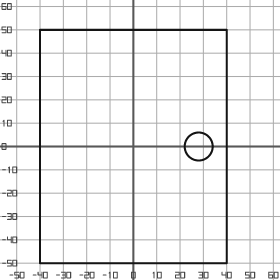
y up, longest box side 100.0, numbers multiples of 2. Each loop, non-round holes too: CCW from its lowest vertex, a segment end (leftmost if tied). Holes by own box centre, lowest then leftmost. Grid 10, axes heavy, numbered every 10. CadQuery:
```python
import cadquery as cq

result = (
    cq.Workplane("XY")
    .moveTo(-40.0, -50.0)
    .lineTo(40.0, -50.0)
    .lineTo(40.0, 50.0)
    .lineTo(-40.0, 50.0)
    .close()
    .moveTo(28.0, 0.0)
    .circle(6.0)
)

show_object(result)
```